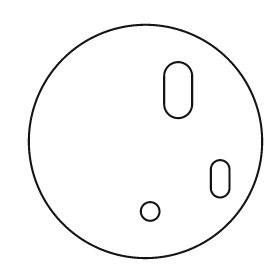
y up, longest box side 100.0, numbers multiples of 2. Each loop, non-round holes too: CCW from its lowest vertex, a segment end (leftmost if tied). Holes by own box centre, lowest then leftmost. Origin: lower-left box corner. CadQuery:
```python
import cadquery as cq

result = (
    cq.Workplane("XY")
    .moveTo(50.0, 50.0)
    .circle(50.0)
    .moveTo(52.0, 20.0)
    .circle(4.0)
    .moveTo(78.0, 30.0)
    .threePointArc((82.0, 26.0), (86.0, 30.0))
    .lineTo(86.0, 38.0)
    .threePointArc((82.0, 42.0), (78.0, 38.0))
    .close()
    .moveTo(58.0, 66.0)
    .threePointArc((64.0, 60.0), (70.0, 66.0))
    .lineTo(70.0, 78.0)
    .threePointArc((64.0, 84.0), (58.0, 78.0))
    .close()
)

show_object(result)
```